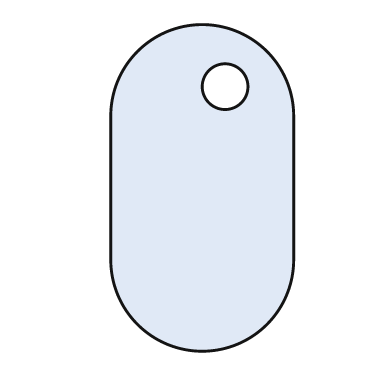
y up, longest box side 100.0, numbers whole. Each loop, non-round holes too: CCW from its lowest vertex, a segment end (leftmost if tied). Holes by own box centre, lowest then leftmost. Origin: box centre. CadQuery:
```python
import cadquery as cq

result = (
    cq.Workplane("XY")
    .moveTo(-28.0, -22.0)
    .threePointArc((0.0, -50.0), (28.0, -22.0))
    .lineTo(28.0, 22.0)
    .threePointArc((0.0, 50.0), (-28.0, 22.0))
    .close()
    .moveTo(7.0, 31.0)
    .circle(7.0)
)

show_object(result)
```